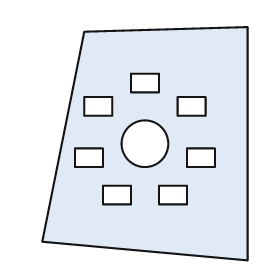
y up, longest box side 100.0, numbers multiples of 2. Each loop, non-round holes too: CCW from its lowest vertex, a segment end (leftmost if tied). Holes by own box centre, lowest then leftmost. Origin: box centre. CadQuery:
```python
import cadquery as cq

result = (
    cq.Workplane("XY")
    .moveTo(44.0, -50.0)
    .lineTo(44.0, 50.0)
    .lineTo(-26.0, 48.0)
    .lineTo(-44.0, -42.0)
    .close()
    .moveTo(-18.0, -26.0)
    .lineTo(-6.0, -26.0)
    .lineTo(-6.0, -18.0)
    .lineTo(-18.0, -18.0)
    .close()
    .moveTo(6.0, -26.0)
    .lineTo(18.0, -26.0)
    .lineTo(18.0, -18.0)
    .lineTo(6.0, -18.0)
    .close()
    .moveTo(-30.0, -10.0)
    .lineTo(-18.0, -10.0)
    .lineTo(-18.0, -2.0)
    .lineTo(-30.0, -2.0)
    .close()
    .moveTo(18.0, -10.0)
    .lineTo(30.0, -10.0)
    .lineTo(30.0, -2.0)
    .lineTo(18.0, -2.0)
    .close()
    .moveTo(0.0, 0.0)
    .circle(10.0)
    .moveTo(-26.0, 12.0)
    .lineTo(-14.0, 12.0)
    .lineTo(-14.0, 20.0)
    .lineTo(-26.0, 20.0)
    .close()
    .moveTo(14.0, 12.0)
    .lineTo(26.0, 12.0)
    .lineTo(26.0, 20.0)
    .lineTo(14.0, 20.0)
    .close()
    .moveTo(-6.0, 22.0)
    .lineTo(6.0, 22.0)
    .lineTo(6.0, 30.0)
    .lineTo(-6.0, 30.0)
    .close()
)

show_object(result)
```